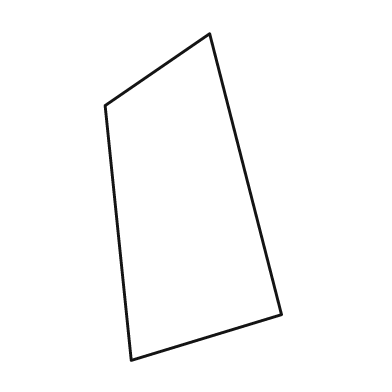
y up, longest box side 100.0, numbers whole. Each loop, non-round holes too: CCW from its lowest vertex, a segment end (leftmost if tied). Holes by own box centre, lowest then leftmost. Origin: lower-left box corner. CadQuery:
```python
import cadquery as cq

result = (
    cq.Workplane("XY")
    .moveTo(8.0, 0.0)
    .lineTo(54.0, 14.0)
    .lineTo(32.0, 100.0)
    .lineTo(0.0, 78.0)
    .close()
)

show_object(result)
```